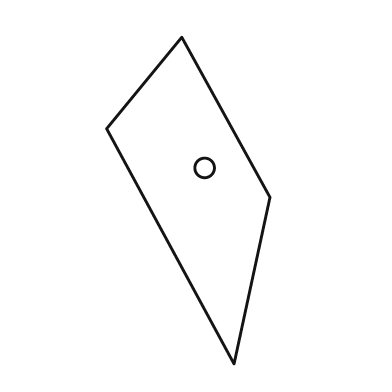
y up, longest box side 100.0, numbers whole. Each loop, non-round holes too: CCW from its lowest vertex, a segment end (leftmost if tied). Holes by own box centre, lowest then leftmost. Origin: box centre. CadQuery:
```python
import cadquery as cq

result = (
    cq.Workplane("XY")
    .moveTo(14.0, -50.0)
    .lineTo(25.0, 1.0)
    .lineTo(-2.0, 50.0)
    .lineTo(-25.0, 22.0)
    .close()
    .moveTo(5.0, 10.0)
    .circle(3.0)
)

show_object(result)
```